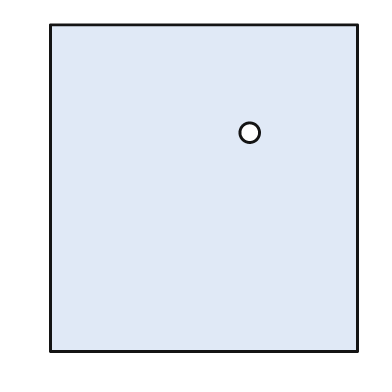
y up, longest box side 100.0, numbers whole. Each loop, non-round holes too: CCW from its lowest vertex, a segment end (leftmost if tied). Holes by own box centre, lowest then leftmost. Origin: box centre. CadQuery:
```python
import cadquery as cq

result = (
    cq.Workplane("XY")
    .moveTo(-47.0, -50.0)
    .lineTo(47.0, -50.0)
    .lineTo(47.0, 50.0)
    .lineTo(-47.0, 50.0)
    .close()
    .moveTo(14.0, 17.0)
    .circle(3.0)
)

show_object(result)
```